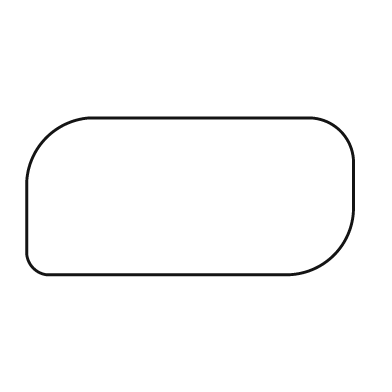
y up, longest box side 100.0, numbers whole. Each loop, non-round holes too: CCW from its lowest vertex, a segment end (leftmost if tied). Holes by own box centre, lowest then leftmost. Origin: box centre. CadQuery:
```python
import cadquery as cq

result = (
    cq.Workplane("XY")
    .moveTo(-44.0, -24.0)
    .lineTo(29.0, -24.0)
    .threePointArc((44.0, -18.0), (50.0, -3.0))
    .lineTo(50.0, 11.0)
    .threePointArc((46.0, 20.0), (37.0, 24.0))
    .lineTo(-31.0, 24.0)
    .threePointArc((-44.0, 18.0), (-50.0, 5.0))
    .lineTo(-50.0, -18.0)
    .threePointArc((-48.0, -22.0), (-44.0, -24.0))
    .close()
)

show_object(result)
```